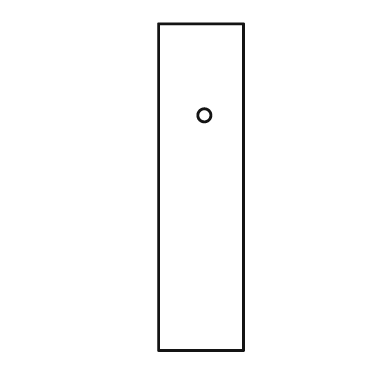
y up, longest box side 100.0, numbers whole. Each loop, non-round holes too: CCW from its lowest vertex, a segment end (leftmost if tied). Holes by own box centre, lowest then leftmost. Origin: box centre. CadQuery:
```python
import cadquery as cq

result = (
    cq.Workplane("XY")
    .moveTo(-13.0, -50.0)
    .lineTo(13.0, -50.0)
    .lineTo(13.0, 50.0)
    .lineTo(-13.0, 50.0)
    .close()
    .moveTo(1.0, 22.0)
    .circle(2.0)
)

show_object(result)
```